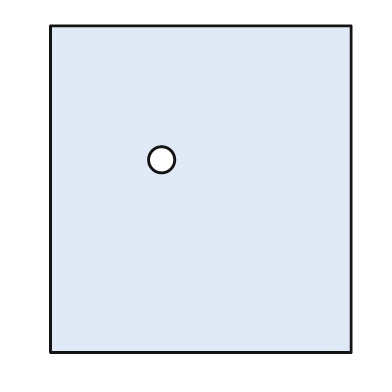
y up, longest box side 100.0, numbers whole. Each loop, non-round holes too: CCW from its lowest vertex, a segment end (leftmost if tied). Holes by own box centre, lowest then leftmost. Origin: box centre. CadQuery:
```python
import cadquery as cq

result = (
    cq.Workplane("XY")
    .moveTo(-46.0, -50.0)
    .lineTo(46.0, -50.0)
    .lineTo(46.0, 50.0)
    .lineTo(-46.0, 50.0)
    .close()
    .moveTo(-12.0, 9.0)
    .circle(4.0)
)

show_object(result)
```